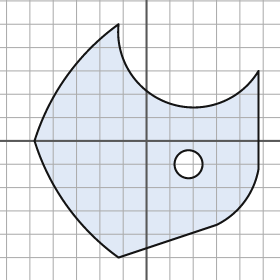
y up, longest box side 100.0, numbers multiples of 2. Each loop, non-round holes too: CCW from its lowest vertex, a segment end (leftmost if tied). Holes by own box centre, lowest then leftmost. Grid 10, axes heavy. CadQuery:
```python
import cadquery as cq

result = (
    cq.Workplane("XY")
    .moveTo(-12.0, -50.0)
    .lineTo(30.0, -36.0)
    .threePointArc((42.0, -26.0), (48.0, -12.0))
    .lineTo(48.0, 30.0)
    .threePointArc((10.0, 16.0), (-12.0, 50.0))
    .threePointArc((-34.0, 28.0), (-48.0, 0.0))
    .threePointArc((-34.0, -28.0), (-12.0, -50.0))
    .close()
    .moveTo(18.0, -10.0)
    .circle(6.0)
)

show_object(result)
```